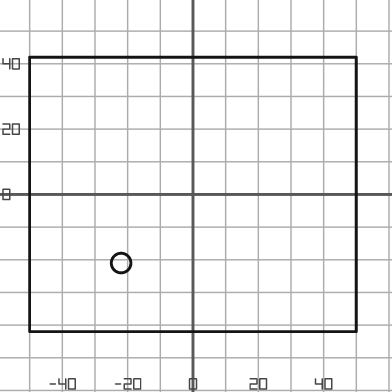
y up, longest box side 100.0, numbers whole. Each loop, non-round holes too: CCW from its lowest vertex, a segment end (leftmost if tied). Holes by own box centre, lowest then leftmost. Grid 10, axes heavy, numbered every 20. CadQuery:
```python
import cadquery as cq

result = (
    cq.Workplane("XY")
    .moveTo(-50.0, -42.0)
    .lineTo(50.0, -42.0)
    .lineTo(50.0, 42.0)
    .lineTo(-50.0, 42.0)
    .close()
    .moveTo(-22.0, -21.0)
    .circle(3.0)
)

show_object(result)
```